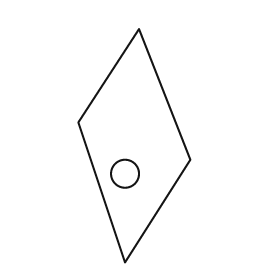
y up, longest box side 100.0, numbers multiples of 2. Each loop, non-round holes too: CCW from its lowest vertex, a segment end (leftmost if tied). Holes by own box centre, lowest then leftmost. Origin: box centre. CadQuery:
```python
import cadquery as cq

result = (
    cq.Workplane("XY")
    .moveTo(-4.0, -50.0)
    .lineTo(24.0, -6.0)
    .lineTo(2.0, 50.0)
    .lineTo(-24.0, 10.0)
    .close()
    .moveTo(-4.0, -12.0)
    .circle(6.0)
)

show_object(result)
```